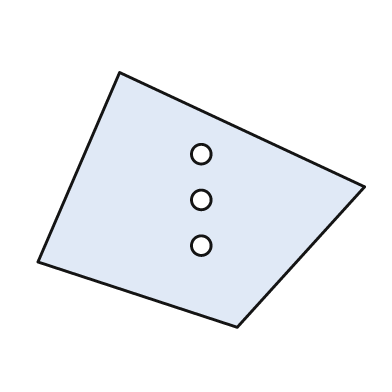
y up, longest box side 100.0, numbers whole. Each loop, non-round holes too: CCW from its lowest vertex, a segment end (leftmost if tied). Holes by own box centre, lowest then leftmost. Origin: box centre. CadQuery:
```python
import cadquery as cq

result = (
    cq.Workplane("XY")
    .moveTo(11.0, -39.0)
    .lineTo(50.0, 4.0)
    .lineTo(-25.0, 39.0)
    .lineTo(-50.0, -19.0)
    .close()
    .moveTo(0.0, -14.0)
    .circle(3.0)
    .moveTo(0.0, 0.0)
    .circle(3.0)
    .moveTo(0.0, 14.0)
    .circle(3.0)
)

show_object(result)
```